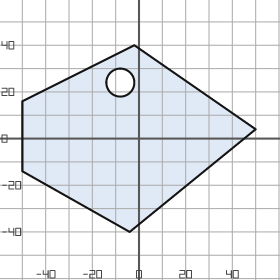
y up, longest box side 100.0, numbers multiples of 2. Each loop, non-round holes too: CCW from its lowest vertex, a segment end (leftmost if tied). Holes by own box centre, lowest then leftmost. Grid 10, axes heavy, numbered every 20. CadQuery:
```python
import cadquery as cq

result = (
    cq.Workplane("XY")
    .moveTo(-4.0, -40.0)
    .lineTo(50.0, 4.0)
    .lineTo(-2.0, 40.0)
    .lineTo(-50.0, 16.0)
    .lineTo(-50.0, -14.0)
    .close()
    .moveTo(-8.0, 24.0)
    .circle(6.0)
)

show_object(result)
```